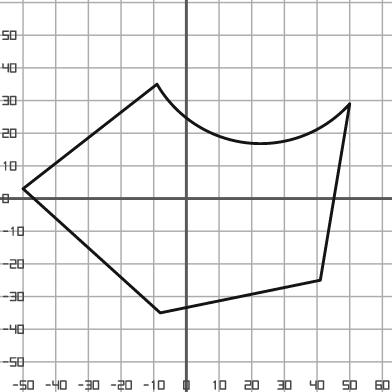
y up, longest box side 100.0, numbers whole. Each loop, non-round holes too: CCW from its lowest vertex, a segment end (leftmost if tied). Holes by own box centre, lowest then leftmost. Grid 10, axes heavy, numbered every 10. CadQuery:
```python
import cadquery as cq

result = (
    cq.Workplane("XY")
    .moveTo(-8.0, -35.0)
    .lineTo(41.0, -25.0)
    .lineTo(50.0, 29.0)
    .threePointArc((19.0, 17.0), (-9.0, 35.0))
    .lineTo(-50.0, 3.0)
    .close()
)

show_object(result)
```